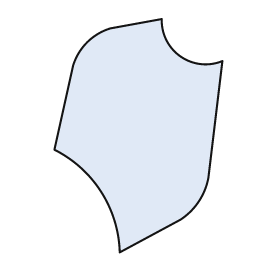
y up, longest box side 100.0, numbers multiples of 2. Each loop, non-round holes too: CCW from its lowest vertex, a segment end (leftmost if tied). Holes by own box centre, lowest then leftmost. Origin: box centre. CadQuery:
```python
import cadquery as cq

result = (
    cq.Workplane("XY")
    .moveTo(-8.0, -50.0)
    .lineTo(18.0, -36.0)
    .threePointArc((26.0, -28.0), (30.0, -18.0))
    .lineTo(36.0, 32.0)
    .threePointArc((18.0, 34.0), (10.0, 50.0))
    .lineTo(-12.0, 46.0)
    .threePointArc((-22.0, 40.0), (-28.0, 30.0))
    .lineTo(-36.0, -6.0)
    .threePointArc((-16.0, -24.0), (-8.0, -50.0))
    .close()
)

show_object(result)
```